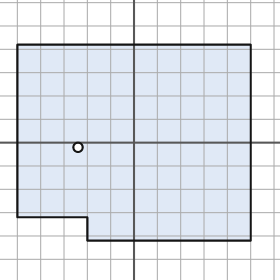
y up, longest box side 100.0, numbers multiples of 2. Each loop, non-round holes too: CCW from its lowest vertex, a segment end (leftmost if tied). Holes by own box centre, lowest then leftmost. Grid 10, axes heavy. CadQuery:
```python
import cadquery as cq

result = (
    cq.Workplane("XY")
    .moveTo(-20.0, -42.0)
    .lineTo(50.0, -42.0)
    .lineTo(50.0, 42.0)
    .lineTo(-50.0, 42.0)
    .lineTo(-50.0, -32.0)
    .lineTo(-20.0, -32.0)
    .close()
    .moveTo(-24.0, -2.0)
    .circle(2.0)
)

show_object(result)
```